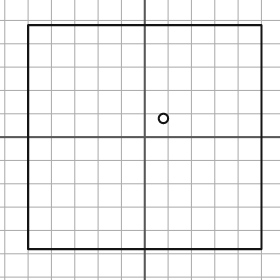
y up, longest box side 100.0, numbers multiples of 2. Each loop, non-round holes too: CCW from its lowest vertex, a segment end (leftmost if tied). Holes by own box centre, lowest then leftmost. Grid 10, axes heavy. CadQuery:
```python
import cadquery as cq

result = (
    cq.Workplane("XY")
    .moveTo(-50.0, -48.0)
    .lineTo(50.0, -48.0)
    .lineTo(50.0, 48.0)
    .lineTo(-50.0, 48.0)
    .close()
    .moveTo(8.0, 8.0)
    .circle(2.0)
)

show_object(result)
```